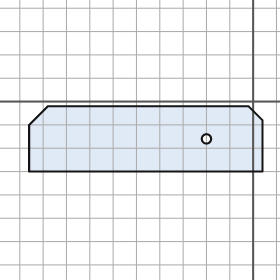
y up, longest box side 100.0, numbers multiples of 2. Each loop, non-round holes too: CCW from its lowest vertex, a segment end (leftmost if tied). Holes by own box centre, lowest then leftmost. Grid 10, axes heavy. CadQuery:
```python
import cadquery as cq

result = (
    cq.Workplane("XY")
    .moveTo(-96.0, -30.0)
    .lineTo(4.0, -30.0)
    .lineTo(4.0, -8.0)
    .lineTo(-2.0, -2.0)
    .lineTo(-88.0, -2.0)
    .lineTo(-96.0, -10.0)
    .close()
    .moveTo(-20.0, -16.0)
    .circle(2.0)
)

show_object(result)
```